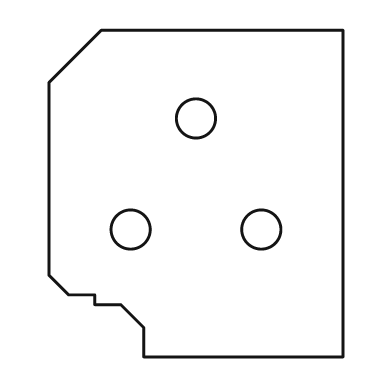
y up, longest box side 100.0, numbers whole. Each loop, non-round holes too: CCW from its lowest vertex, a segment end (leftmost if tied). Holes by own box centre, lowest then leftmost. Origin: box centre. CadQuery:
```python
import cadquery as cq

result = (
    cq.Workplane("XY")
    .moveTo(-16.0, -50.0)
    .lineTo(45.0, -50.0)
    .lineTo(45.0, 50.0)
    .lineTo(-29.0, 50.0)
    .lineTo(-45.0, 34.0)
    .lineTo(-45.0, -25.0)
    .lineTo(-39.0, -31.0)
    .lineTo(-31.0, -31.0)
    .lineTo(-31.0, -34.0)
    .lineTo(-23.0, -34.0)
    .lineTo(-16.0, -41.0)
    .close()
    .moveTo(-20.0, -11.0)
    .circle(6.0)
    .moveTo(20.0, -11.0)
    .circle(6.0)
    .moveTo(0.0, 23.0)
    .circle(6.0)
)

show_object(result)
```